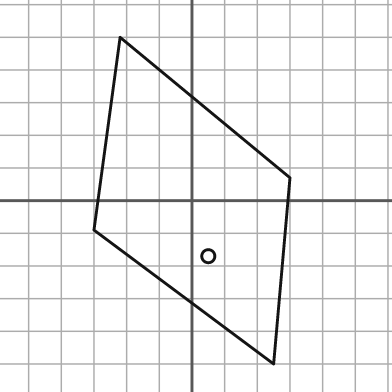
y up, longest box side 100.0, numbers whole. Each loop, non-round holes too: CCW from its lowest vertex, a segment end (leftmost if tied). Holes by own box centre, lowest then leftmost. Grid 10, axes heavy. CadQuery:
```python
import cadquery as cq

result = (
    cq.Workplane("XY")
    .moveTo(25.0, -50.0)
    .lineTo(30.0, 7.0)
    .lineTo(-22.0, 50.0)
    .lineTo(-30.0, -9.0)
    .close()
    .moveTo(5.0, -17.0)
    .circle(2.0)
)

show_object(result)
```